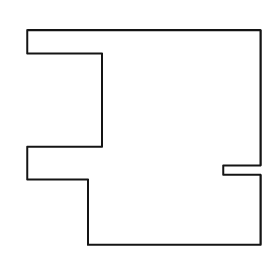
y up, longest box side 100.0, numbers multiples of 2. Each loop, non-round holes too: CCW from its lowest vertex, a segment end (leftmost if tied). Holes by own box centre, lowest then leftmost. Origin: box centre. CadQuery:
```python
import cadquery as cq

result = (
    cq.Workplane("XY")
    .moveTo(-24.0, -46.0)
    .lineTo(50.0, -46.0)
    .lineTo(50.0, -16.0)
    .lineTo(34.0, -16.0)
    .lineTo(34.0, -12.0)
    .lineTo(50.0, -12.0)
    .lineTo(50.0, 46.0)
    .lineTo(-50.0, 46.0)
    .lineTo(-50.0, 36.0)
    .lineTo(-18.0, 36.0)
    .lineTo(-18.0, -4.0)
    .lineTo(-50.0, -4.0)
    .lineTo(-50.0, -18.0)
    .lineTo(-24.0, -18.0)
    .close()
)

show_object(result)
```